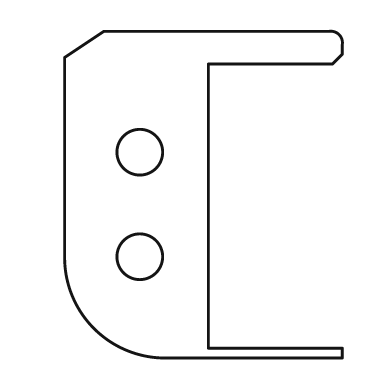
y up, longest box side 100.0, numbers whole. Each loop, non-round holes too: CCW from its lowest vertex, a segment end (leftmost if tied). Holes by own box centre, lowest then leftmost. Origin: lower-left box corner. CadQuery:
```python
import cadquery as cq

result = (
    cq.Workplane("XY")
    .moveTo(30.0, 0.0)
    .lineTo(85.0, 0.0)
    .lineTo(85.0, 3.0)
    .lineTo(44.0, 3.0)
    .lineTo(44.0, 90.0)
    .lineTo(82.0, 90.0)
    .lineTo(85.0, 93.0)
    .lineTo(85.0, 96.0)
    .threePointArc((84.0, 99.0), (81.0, 100.0))
    .lineTo(12.0, 100.0)
    .lineTo(0.0, 92.0)
    .lineTo(0.0, 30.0)
    .threePointArc((9.0, 9.0), (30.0, 0.0))
    .close()
    .moveTo(23.0, 31.0)
    .circle(7.0)
    .moveTo(23.0, 63.0)
    .circle(7.0)
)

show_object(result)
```